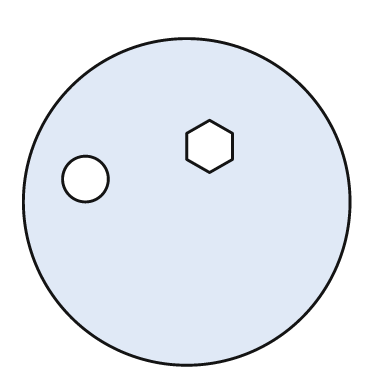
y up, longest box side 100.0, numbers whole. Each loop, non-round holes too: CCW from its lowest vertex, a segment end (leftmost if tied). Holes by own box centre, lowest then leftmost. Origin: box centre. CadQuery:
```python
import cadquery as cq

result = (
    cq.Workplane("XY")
    .moveTo(0.0, 0.0)
    .circle(50.0)
    .moveTo(-31.0, 7.0)
    .circle(7.0)
    .moveTo(7.0, 9.0)
    .lineTo(14.0, 13.0)
    .lineTo(14.0, 21.0)
    .lineTo(7.0, 25.0)
    .lineTo(0.0, 21.0)
    .lineTo(0.0, 13.0)
    .close()
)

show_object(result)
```